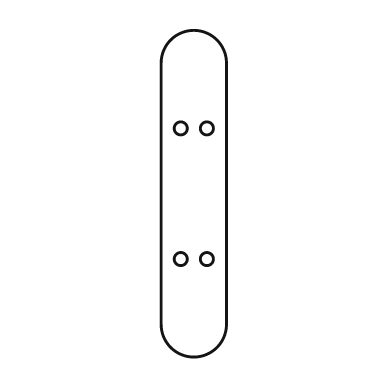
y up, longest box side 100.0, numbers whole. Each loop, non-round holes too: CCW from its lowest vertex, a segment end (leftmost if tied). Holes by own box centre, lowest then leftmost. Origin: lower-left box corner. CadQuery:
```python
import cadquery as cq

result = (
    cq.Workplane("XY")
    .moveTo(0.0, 10.0)
    .threePointArc((10.0, 0.0), (20.0, 10.0))
    .lineTo(20.0, 90.0)
    .threePointArc((10.0, 100.0), (0.0, 90.0))
    .close()
    .moveTo(6.0, 30.0)
    .circle(2.0)
    .moveTo(14.0, 30.0)
    .circle(2.0)
    .moveTo(6.0, 70.0)
    .circle(2.0)
    .moveTo(14.0, 70.0)
    .circle(2.0)
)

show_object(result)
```